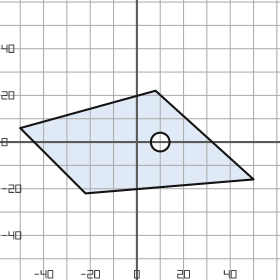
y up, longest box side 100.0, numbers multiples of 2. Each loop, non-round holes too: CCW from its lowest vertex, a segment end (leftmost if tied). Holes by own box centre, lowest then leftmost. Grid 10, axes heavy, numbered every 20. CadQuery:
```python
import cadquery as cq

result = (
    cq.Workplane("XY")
    .moveTo(-22.0, -22.0)
    .lineTo(50.0, -16.0)
    .lineTo(8.0, 22.0)
    .lineTo(-50.0, 6.0)
    .close()
    .moveTo(10.0, 0.0)
    .circle(4.0)
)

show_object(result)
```